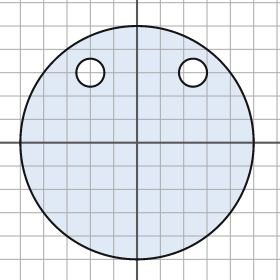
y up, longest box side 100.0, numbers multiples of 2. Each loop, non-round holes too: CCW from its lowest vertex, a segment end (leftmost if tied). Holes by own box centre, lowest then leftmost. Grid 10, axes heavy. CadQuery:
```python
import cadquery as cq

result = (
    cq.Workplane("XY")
    .moveTo(0.0, 0.0)
    .circle(50.0)
    .moveTo(-20.0, 30.0)
    .circle(6.0)
    .moveTo(24.0, 30.0)
    .circle(6.0)
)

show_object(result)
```